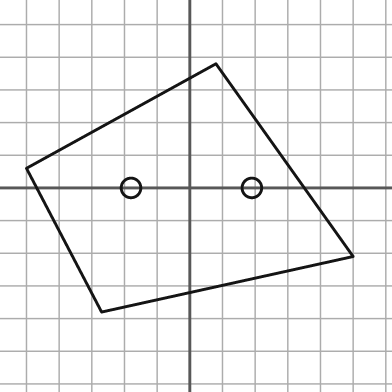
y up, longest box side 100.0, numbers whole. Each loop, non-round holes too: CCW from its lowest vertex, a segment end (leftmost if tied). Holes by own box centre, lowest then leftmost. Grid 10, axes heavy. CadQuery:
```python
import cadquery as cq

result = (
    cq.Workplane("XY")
    .moveTo(-27.0, -38.0)
    .lineTo(50.0, -21.0)
    .lineTo(8.0, 38.0)
    .lineTo(-50.0, 6.0)
    .close()
    .moveTo(-18.0, 0.0)
    .circle(3.0)
    .moveTo(19.0, 0.0)
    .circle(3.0)
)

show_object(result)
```